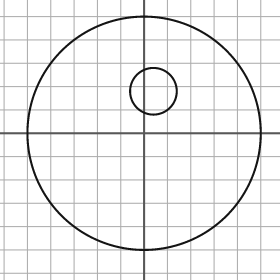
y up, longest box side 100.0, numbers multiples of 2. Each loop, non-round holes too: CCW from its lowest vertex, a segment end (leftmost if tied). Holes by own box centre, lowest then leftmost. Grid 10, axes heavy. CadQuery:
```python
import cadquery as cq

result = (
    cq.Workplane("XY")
    .moveTo(0.0, 0.0)
    .circle(50.0)
    .moveTo(4.0, 18.0)
    .circle(10.0)
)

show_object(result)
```